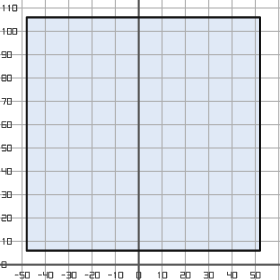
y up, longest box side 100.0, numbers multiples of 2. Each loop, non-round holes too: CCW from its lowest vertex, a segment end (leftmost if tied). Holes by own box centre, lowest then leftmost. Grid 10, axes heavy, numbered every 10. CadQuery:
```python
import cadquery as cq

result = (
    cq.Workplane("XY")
    .moveTo(-48.0, 6.0)
    .lineTo(52.0, 6.0)
    .lineTo(52.0, 106.0)
    .lineTo(-48.0, 106.0)
    .close()
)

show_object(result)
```